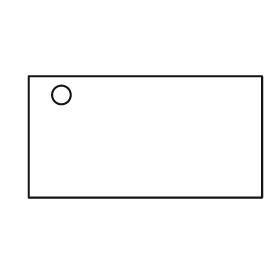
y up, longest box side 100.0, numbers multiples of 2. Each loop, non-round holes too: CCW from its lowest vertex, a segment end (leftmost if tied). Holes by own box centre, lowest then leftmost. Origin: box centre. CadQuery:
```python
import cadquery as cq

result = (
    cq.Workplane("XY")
    .moveTo(-50.0, -26.0)
    .lineTo(50.0, -26.0)
    .lineTo(50.0, 26.0)
    .lineTo(-50.0, 26.0)
    .close()
    .moveTo(-36.0, 18.0)
    .circle(4.0)
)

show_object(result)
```